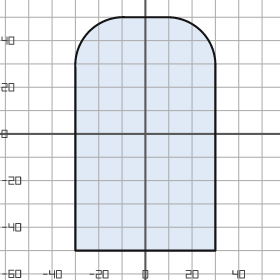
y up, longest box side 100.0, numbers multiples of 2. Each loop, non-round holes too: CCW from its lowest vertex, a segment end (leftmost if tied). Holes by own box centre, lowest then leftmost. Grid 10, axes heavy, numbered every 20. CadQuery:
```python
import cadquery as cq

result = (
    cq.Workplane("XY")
    .moveTo(-30.0, -50.0)
    .lineTo(30.0, -50.0)
    .lineTo(30.0, 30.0)
    .threePointArc((24.0, 44.0), (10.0, 50.0))
    .lineTo(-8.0, 50.0)
    .threePointArc((-24.0, 44.0), (-30.0, 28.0))
    .close()
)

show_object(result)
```